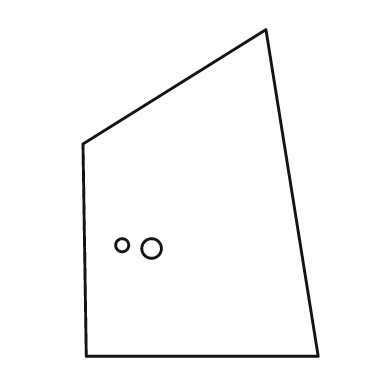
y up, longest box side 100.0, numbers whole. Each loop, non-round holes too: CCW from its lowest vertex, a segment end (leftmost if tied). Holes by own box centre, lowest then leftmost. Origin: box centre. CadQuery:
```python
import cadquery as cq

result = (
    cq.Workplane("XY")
    .moveTo(-35.0, -50.0)
    .lineTo(36.0, -50.0)
    .lineTo(20.0, 50.0)
    .lineTo(-36.0, 15.0)
    .close()
    .moveTo(-15.0, -17.0)
    .circle(3.0)
    .moveTo(-24.0, -16.0)
    .circle(2.0)
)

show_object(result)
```